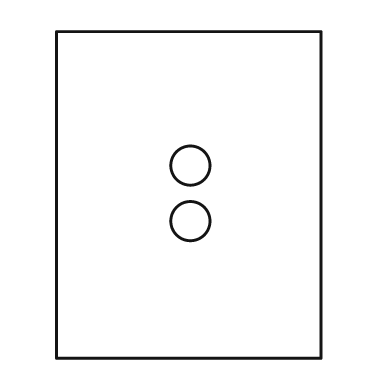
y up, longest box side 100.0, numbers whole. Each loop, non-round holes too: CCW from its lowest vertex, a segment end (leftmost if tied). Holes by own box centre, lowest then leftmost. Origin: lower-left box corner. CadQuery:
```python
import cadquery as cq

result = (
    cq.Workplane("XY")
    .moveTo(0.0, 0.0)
    .lineTo(81.0, 0.0)
    .lineTo(81.0, 100.0)
    .lineTo(0.0, 100.0)
    .close()
    .moveTo(41.0, 42.0)
    .circle(6.0)
    .moveTo(41.0, 59.0)
    .circle(6.0)
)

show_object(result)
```